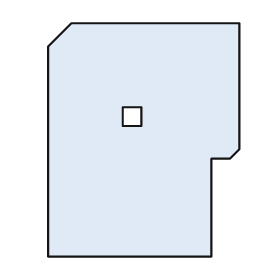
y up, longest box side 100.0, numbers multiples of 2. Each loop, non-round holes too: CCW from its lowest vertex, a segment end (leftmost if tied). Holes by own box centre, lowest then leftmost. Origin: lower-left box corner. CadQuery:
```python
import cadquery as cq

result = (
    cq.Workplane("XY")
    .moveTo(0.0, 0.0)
    .lineTo(70.0, 0.0)
    .lineTo(70.0, 42.0)
    .lineTo(78.0, 42.0)
    .lineTo(82.0, 46.0)
    .lineTo(82.0, 100.0)
    .lineTo(10.0, 100.0)
    .lineTo(0.0, 90.0)
    .close()
    .moveTo(32.0, 56.0)
    .lineTo(40.0, 56.0)
    .lineTo(40.0, 64.0)
    .lineTo(32.0, 64.0)
    .close()
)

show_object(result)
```